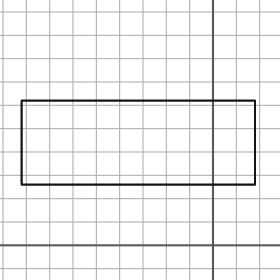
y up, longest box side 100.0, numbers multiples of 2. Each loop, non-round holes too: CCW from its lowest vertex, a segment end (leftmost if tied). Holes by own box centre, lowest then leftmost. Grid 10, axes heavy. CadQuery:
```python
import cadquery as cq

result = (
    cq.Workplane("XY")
    .moveTo(-82.0, 26.0)
    .lineTo(18.0, 26.0)
    .lineTo(18.0, 62.0)
    .lineTo(-82.0, 62.0)
    .close()
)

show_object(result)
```